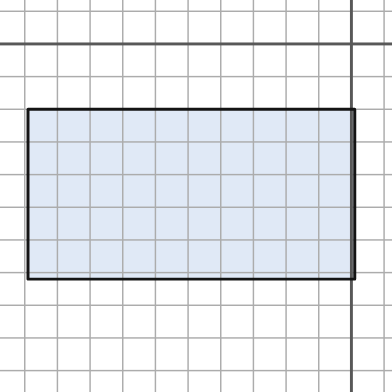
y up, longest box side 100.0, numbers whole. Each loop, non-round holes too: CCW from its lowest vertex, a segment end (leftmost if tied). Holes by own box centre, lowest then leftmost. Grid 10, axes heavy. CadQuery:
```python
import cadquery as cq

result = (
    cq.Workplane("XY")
    .moveTo(-99.0, -72.0)
    .lineTo(1.0, -72.0)
    .lineTo(1.0, -20.0)
    .lineTo(-99.0, -20.0)
    .close()
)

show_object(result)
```